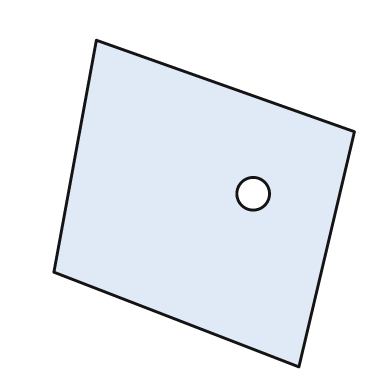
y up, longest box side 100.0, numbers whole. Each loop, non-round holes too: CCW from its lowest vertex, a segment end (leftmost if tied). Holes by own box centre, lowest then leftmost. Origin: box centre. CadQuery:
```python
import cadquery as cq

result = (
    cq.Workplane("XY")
    .moveTo(29.0, -50.0)
    .lineTo(46.0, 22.0)
    .lineTo(-33.0, 50.0)
    .lineTo(-46.0, -21.0)
    .close()
    .moveTo(15.0, 3.0)
    .circle(5.0)
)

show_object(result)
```